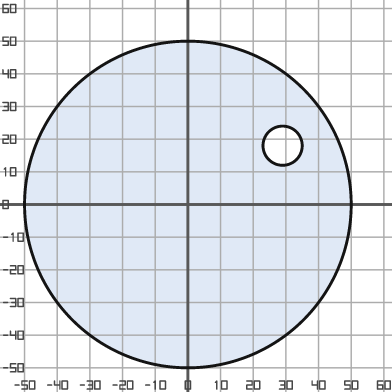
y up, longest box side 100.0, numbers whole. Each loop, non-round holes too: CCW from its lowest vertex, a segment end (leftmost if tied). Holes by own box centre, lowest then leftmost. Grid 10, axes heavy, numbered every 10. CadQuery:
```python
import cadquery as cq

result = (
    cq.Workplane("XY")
    .moveTo(0.0, 0.0)
    .circle(50.0)
    .moveTo(29.0, 18.0)
    .circle(6.0)
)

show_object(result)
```